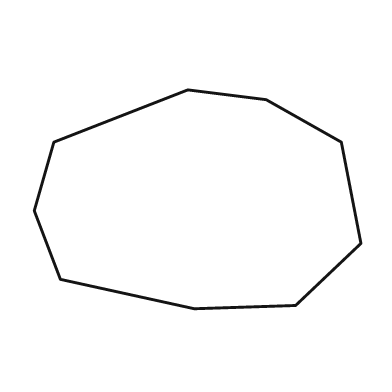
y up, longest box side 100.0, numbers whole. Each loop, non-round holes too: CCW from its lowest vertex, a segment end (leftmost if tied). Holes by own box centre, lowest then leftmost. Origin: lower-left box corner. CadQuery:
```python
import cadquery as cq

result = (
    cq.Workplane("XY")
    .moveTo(49.0, 0.0)
    .lineTo(80.0, 1.0)
    .lineTo(100.0, 20.0)
    .lineTo(94.0, 51.0)
    .lineTo(71.0, 64.0)
    .lineTo(47.0, 67.0)
    .lineTo(6.0, 51.0)
    .lineTo(0.0, 30.0)
    .lineTo(8.0, 9.0)
    .close()
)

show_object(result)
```